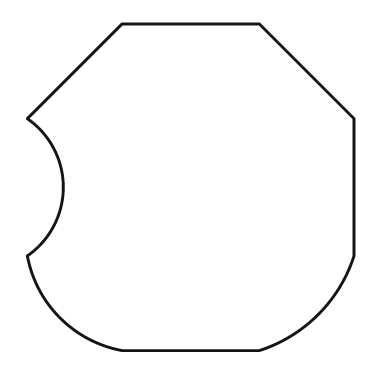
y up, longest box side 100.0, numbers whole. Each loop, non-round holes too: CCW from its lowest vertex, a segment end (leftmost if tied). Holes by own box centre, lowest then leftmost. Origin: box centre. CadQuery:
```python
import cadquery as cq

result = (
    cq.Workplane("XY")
    .moveTo(-21.0, -50.0)
    .lineTo(21.0, -50.0)
    .threePointArc((39.0, -39.0), (50.0, -21.0))
    .lineTo(50.0, 21.0)
    .lineTo(21.0, 50.0)
    .lineTo(-21.0, 50.0)
    .lineTo(-50.0, 21.0)
    .threePointArc((-39.0, 0.0), (-50.0, -21.0))
    .threePointArc((-40.0, -40.0), (-21.0, -50.0))
    .close()
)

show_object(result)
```